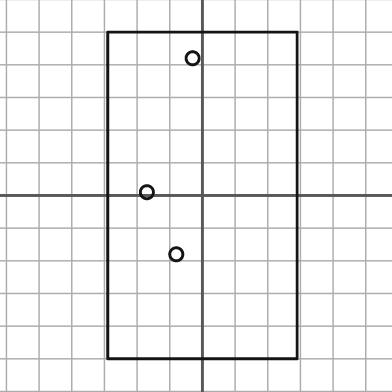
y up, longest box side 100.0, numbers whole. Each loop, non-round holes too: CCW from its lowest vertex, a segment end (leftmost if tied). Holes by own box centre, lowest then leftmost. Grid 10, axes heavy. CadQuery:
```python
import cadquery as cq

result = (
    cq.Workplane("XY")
    .moveTo(-29.0, -50.0)
    .lineTo(29.0, -50.0)
    .lineTo(29.0, 50.0)
    .lineTo(-29.0, 50.0)
    .close()
    .moveTo(-8.0, -18.0)
    .circle(2.0)
    .moveTo(-17.0, 1.0)
    .circle(2.0)
    .moveTo(-3.0, 42.0)
    .circle(2.0)
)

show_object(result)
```